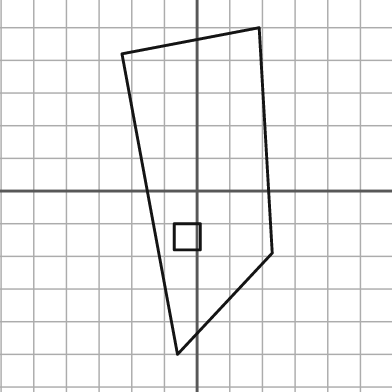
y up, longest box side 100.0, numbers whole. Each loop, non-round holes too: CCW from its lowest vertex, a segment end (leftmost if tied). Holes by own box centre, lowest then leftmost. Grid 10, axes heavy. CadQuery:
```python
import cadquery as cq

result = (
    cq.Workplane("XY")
    .moveTo(-6.0, -50.0)
    .lineTo(23.0, -19.0)
    .lineTo(19.0, 50.0)
    .lineTo(-23.0, 42.0)
    .close()
    .moveTo(-7.0, -18.0)
    .lineTo(1.0, -18.0)
    .lineTo(1.0, -10.0)
    .lineTo(-7.0, -10.0)
    .close()
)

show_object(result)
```